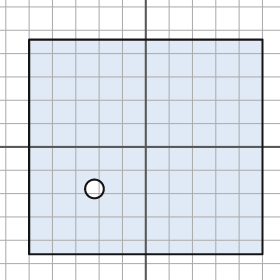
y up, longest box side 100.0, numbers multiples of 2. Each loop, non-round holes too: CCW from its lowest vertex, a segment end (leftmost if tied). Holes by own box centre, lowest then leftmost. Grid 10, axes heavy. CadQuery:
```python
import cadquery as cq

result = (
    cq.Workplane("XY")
    .moveTo(-50.0, -46.0)
    .lineTo(50.0, -46.0)
    .lineTo(50.0, 46.0)
    .lineTo(-50.0, 46.0)
    .close()
    .moveTo(-22.0, -18.0)
    .circle(4.0)
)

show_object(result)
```